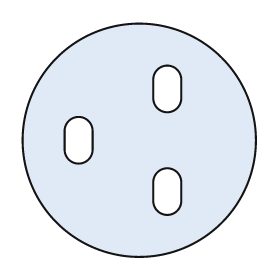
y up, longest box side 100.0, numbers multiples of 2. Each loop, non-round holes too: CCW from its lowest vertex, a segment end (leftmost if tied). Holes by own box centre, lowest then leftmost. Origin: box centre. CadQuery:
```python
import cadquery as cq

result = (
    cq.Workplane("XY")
    .moveTo(0.0, 0.0)
    .circle(50.0)
    .moveTo(6.0, -26.0)
    .threePointArc((12.0, -32.0), (18.0, -26.0))
    .lineTo(18.0, -18.0)
    .threePointArc((12.0, -12.0), (6.0, -18.0))
    .close()
    .moveTo(-32.0, -4.0)
    .threePointArc((-26.0, -10.0), (-20.0, -4.0))
    .lineTo(-20.0, 4.0)
    .threePointArc((-26.0, 10.0), (-32.0, 4.0))
    .close()
    .moveTo(6.0, 18.0)
    .threePointArc((12.0, 12.0), (18.0, 18.0))
    .lineTo(18.0, 26.0)
    .threePointArc((12.0, 32.0), (6.0, 26.0))
    .close()
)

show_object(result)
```